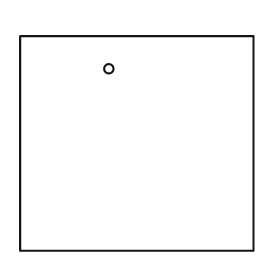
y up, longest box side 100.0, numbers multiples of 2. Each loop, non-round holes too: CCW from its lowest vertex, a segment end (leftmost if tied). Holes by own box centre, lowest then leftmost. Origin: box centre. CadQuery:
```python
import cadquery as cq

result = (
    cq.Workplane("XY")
    .moveTo(-50.0, -46.0)
    .lineTo(50.0, -46.0)
    .lineTo(50.0, 46.0)
    .lineTo(-50.0, 46.0)
    .close()
    .moveTo(-12.0, 32.0)
    .circle(2.0)
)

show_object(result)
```